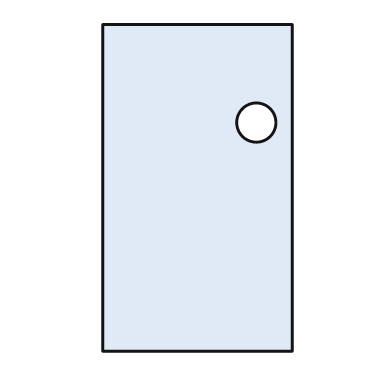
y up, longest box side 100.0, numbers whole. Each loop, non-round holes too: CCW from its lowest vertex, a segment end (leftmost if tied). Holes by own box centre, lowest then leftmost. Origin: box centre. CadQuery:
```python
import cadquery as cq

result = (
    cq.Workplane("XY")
    .moveTo(-29.0, -50.0)
    .lineTo(29.0, -50.0)
    .lineTo(29.0, 50.0)
    .lineTo(-29.0, 50.0)
    .close()
    .moveTo(18.0, 20.0)
    .circle(6.0)
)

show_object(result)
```